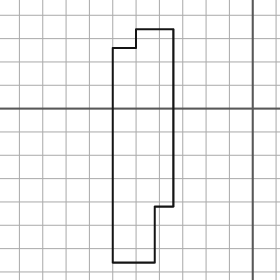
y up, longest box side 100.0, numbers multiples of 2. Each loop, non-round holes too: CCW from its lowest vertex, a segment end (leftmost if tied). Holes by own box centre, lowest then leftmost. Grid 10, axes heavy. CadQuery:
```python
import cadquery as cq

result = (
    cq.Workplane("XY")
    .moveTo(-60.0, -66.0)
    .lineTo(-42.0, -66.0)
    .lineTo(-42.0, -42.0)
    .lineTo(-34.0, -42.0)
    .lineTo(-34.0, 34.0)
    .lineTo(-50.0, 34.0)
    .lineTo(-50.0, 26.0)
    .lineTo(-60.0, 26.0)
    .close()
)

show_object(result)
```